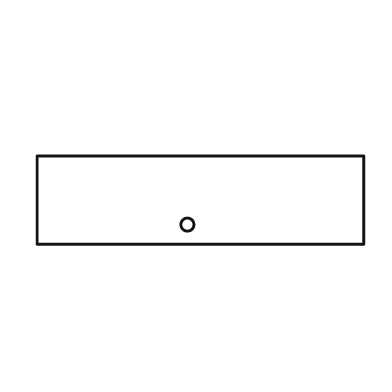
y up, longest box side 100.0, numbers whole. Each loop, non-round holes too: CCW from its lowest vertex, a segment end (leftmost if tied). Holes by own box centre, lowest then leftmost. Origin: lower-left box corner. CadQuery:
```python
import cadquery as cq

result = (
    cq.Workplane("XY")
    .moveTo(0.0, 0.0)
    .lineTo(100.0, 0.0)
    .lineTo(100.0, 27.0)
    .lineTo(0.0, 27.0)
    .close()
    .moveTo(46.0, 6.0)
    .circle(2.0)
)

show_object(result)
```